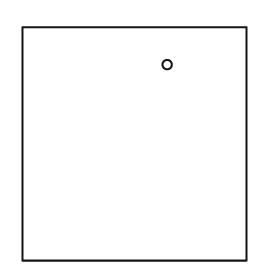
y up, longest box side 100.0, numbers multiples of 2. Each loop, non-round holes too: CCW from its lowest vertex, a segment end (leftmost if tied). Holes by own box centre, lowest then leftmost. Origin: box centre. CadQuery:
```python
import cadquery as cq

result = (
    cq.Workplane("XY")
    .moveTo(-48.0, -50.0)
    .lineTo(48.0, -50.0)
    .lineTo(48.0, 50.0)
    .lineTo(-48.0, 50.0)
    .close()
    .moveTo(14.0, 34.0)
    .circle(2.0)
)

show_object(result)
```